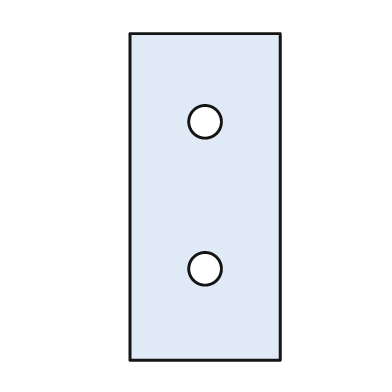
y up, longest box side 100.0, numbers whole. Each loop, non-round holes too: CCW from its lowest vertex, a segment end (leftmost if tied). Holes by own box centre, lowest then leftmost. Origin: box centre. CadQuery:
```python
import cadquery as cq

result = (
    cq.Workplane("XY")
    .moveTo(-23.0, -50.0)
    .lineTo(23.0, -50.0)
    .lineTo(23.0, 50.0)
    .lineTo(-23.0, 50.0)
    .close()
    .moveTo(0.0, -22.0)
    .circle(5.0)
    .moveTo(0.0, 23.0)
    .circle(5.0)
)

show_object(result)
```